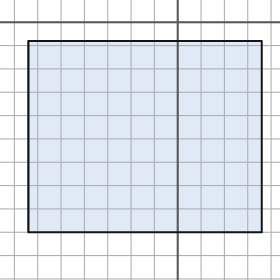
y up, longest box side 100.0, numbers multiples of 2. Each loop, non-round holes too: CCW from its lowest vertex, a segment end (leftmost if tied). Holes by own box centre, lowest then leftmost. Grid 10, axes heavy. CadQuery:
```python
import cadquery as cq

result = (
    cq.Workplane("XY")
    .moveTo(-64.0, -90.0)
    .lineTo(36.0, -90.0)
    .lineTo(36.0, -8.0)
    .lineTo(-64.0, -8.0)
    .close()
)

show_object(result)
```